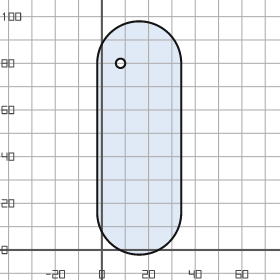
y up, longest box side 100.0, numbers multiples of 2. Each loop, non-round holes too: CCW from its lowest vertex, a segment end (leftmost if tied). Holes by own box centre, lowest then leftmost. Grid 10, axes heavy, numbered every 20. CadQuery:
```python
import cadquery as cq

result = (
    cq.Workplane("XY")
    .moveTo(-2.0, 16.0)
    .threePointArc((16.0, -2.0), (34.0, 16.0))
    .lineTo(34.0, 80.0)
    .threePointArc((16.0, 98.0), (-2.0, 80.0))
    .close()
    .moveTo(8.0, 80.0)
    .circle(2.0)
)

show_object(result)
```